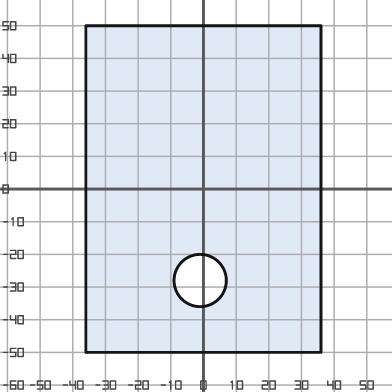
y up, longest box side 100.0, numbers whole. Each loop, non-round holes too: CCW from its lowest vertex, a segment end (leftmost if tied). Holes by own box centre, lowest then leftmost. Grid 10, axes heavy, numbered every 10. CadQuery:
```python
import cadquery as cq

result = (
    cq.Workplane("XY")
    .moveTo(-36.0, -50.0)
    .lineTo(36.0, -50.0)
    .lineTo(36.0, 50.0)
    .lineTo(-36.0, 50.0)
    .close()
    .moveTo(-1.0, -28.0)
    .circle(8.0)
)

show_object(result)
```